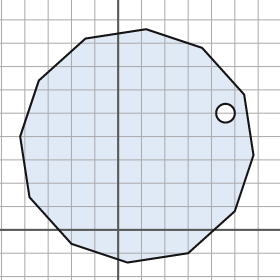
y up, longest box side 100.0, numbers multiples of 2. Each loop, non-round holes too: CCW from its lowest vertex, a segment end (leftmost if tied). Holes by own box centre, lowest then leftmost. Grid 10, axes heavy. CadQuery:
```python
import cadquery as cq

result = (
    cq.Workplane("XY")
    .moveTo(4.0, -14.0)
    .lineTo(30.0, -10.0)
    .lineTo(50.0, 8.0)
    .lineTo(58.0, 32.0)
    .lineTo(54.0, 58.0)
    .lineTo(36.0, 78.0)
    .lineTo(12.0, 86.0)
    .lineTo(-14.0, 82.0)
    .lineTo(-34.0, 64.0)
    .lineTo(-42.0, 40.0)
    .lineTo(-38.0, 14.0)
    .lineTo(-20.0, -6.0)
    .close()
    .moveTo(46.0, 50.0)
    .circle(4.0)
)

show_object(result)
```